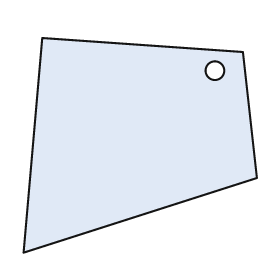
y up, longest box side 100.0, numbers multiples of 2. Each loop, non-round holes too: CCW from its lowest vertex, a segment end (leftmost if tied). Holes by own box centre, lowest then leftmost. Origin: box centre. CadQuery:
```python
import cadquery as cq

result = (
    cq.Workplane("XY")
    .moveTo(-50.0, -46.0)
    .lineTo(50.0, -14.0)
    .lineTo(44.0, 40.0)
    .lineTo(-42.0, 46.0)
    .close()
    .moveTo(32.0, 32.0)
    .circle(4.0)
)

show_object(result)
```